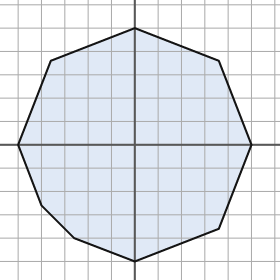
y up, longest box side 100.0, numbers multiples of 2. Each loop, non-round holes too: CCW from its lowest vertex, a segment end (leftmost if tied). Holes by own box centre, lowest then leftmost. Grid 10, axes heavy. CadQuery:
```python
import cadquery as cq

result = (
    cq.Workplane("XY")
    .moveTo(0.0, -50.0)
    .lineTo(36.0, -36.0)
    .lineTo(50.0, 0.0)
    .lineTo(36.0, 36.0)
    .lineTo(0.0, 50.0)
    .lineTo(-36.0, 36.0)
    .lineTo(-50.0, 0.0)
    .lineTo(-40.0, -26.0)
    .lineTo(-26.0, -40.0)
    .close()
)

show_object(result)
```